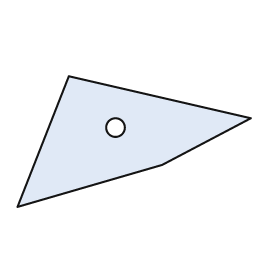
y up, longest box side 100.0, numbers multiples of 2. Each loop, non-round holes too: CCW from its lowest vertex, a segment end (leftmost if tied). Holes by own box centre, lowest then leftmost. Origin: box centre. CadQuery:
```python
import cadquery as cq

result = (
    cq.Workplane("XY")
    .moveTo(-50.0, -28.0)
    .lineTo(12.0, -10.0)
    .lineTo(50.0, 10.0)
    .lineTo(-28.0, 28.0)
    .close()
    .moveTo(-8.0, 6.0)
    .circle(4.0)
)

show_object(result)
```